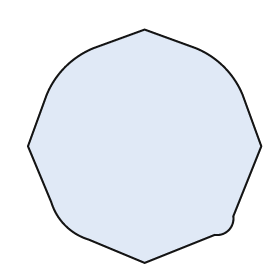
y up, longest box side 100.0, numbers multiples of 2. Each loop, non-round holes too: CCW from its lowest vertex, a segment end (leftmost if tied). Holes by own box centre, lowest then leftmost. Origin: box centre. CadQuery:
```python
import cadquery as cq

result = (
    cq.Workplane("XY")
    .moveTo(0.0, -50.0)
    .lineTo(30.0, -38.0)
    .threePointArc((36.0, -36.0), (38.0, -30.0))
    .lineTo(50.0, 0.0)
    .lineTo(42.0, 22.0)
    .threePointArc((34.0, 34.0), (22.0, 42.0))
    .lineTo(0.0, 50.0)
    .lineTo(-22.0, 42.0)
    .threePointArc((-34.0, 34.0), (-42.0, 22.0))
    .lineTo(-50.0, 0.0)
    .lineTo(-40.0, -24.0)
    .threePointArc((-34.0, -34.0), (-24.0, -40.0))
    .close()
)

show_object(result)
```